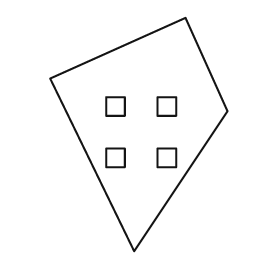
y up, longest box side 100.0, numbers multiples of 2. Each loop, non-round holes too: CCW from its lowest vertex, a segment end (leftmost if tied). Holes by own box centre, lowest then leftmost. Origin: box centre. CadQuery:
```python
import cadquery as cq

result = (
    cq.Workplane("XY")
    .moveTo(-2.0, -50.0)
    .lineTo(38.0, 10.0)
    .lineTo(20.0, 50.0)
    .lineTo(-38.0, 24.0)
    .close()
    .moveTo(-14.0, -14.0)
    .lineTo(-6.0, -14.0)
    .lineTo(-6.0, -6.0)
    .lineTo(-14.0, -6.0)
    .close()
    .moveTo(8.0, -14.0)
    .lineTo(16.0, -14.0)
    .lineTo(16.0, -6.0)
    .lineTo(8.0, -6.0)
    .close()
    .moveTo(-14.0, 8.0)
    .lineTo(-6.0, 8.0)
    .lineTo(-6.0, 16.0)
    .lineTo(-14.0, 16.0)
    .close()
    .moveTo(8.0, 8.0)
    .lineTo(16.0, 8.0)
    .lineTo(16.0, 16.0)
    .lineTo(8.0, 16.0)
    .close()
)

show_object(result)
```